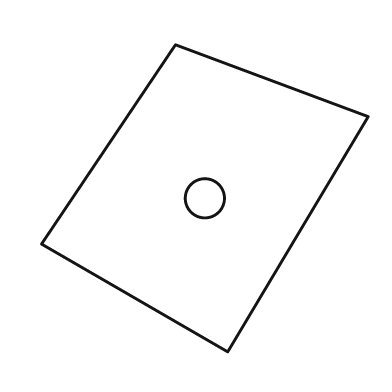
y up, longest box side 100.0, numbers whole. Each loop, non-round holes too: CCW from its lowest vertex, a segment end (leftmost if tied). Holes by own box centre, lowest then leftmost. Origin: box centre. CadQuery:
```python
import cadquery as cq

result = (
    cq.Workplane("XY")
    .moveTo(7.0, -47.0)
    .lineTo(50.0, 25.0)
    .lineTo(-9.0, 47.0)
    .lineTo(-50.0, -14.0)
    .close()
    .moveTo(0.0, 0.0)
    .circle(6.0)
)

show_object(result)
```